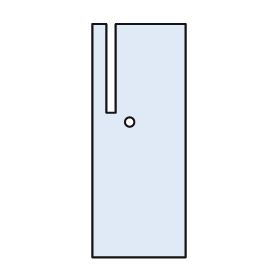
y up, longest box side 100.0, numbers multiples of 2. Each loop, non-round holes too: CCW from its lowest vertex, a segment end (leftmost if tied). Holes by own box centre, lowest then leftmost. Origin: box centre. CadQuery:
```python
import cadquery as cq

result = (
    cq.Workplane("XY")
    .moveTo(-20.0, -50.0)
    .lineTo(20.0, -50.0)
    .lineTo(20.0, 50.0)
    .lineTo(-10.0, 50.0)
    .lineTo(-10.0, 12.0)
    .lineTo(-14.0, 12.0)
    .lineTo(-14.0, 50.0)
    .lineTo(-20.0, 50.0)
    .close()
    .moveTo(-4.0, 8.0)
    .circle(2.0)
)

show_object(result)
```